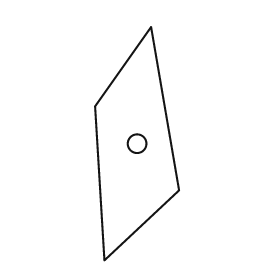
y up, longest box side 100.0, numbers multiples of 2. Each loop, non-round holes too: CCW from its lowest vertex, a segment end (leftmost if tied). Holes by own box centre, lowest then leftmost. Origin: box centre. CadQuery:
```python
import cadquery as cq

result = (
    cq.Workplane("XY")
    .moveTo(-14.0, -50.0)
    .lineTo(18.0, -20.0)
    .lineTo(6.0, 50.0)
    .lineTo(-18.0, 16.0)
    .close()
    .moveTo(0.0, 0.0)
    .circle(4.0)
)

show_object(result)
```